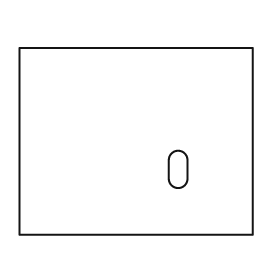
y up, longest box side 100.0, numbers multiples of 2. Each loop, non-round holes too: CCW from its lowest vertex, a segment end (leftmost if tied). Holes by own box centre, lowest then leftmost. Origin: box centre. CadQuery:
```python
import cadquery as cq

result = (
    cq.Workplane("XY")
    .moveTo(-50.0, -40.0)
    .lineTo(50.0, -40.0)
    .lineTo(50.0, 40.0)
    .lineTo(-50.0, 40.0)
    .close()
    .moveTo(14.0, -16.0)
    .threePointArc((18.0, -20.0), (22.0, -16.0))
    .lineTo(22.0, -8.0)
    .threePointArc((18.0, -4.0), (14.0, -8.0))
    .close()
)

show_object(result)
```